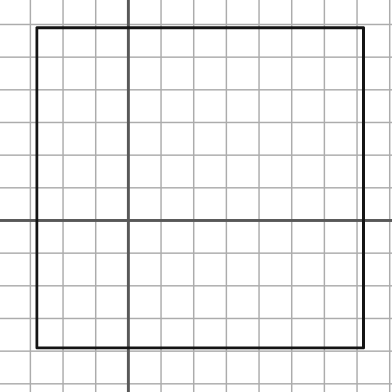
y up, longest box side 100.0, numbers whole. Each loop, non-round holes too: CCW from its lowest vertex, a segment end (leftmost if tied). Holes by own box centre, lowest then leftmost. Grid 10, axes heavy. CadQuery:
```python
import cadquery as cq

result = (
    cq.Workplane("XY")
    .moveTo(-28.0, -39.0)
    .lineTo(72.0, -39.0)
    .lineTo(72.0, 59.0)
    .lineTo(-28.0, 59.0)
    .close()
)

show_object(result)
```